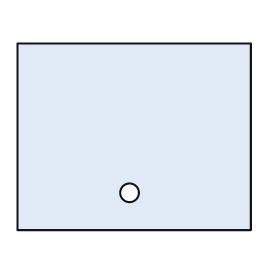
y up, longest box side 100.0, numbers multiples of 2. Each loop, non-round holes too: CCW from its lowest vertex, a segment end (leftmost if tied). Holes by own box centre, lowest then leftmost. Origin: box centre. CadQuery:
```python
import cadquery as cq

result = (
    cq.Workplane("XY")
    .moveTo(-50.0, -40.0)
    .lineTo(50.0, -40.0)
    .lineTo(50.0, 40.0)
    .lineTo(-50.0, 40.0)
    .close()
    .moveTo(-2.0, -24.0)
    .circle(4.0)
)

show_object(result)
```